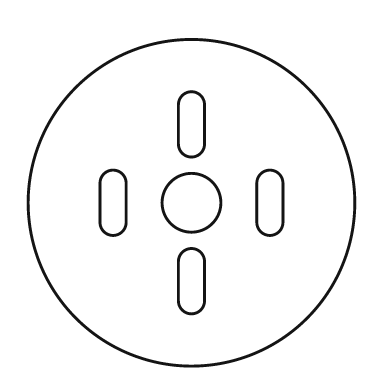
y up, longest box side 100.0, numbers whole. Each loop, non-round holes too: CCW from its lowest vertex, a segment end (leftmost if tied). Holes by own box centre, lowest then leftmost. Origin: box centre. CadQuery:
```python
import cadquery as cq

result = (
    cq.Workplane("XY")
    .moveTo(0.0, 0.0)
    .circle(50.0)
    .moveTo(-4.0, -30.0)
    .threePointArc((0.0, -34.0), (4.0, -30.0))
    .lineTo(4.0, -18.0)
    .threePointArc((0.0, -14.0), (-4.0, -18.0))
    .close()
    .moveTo(-28.0, -6.0)
    .threePointArc((-24.0, -10.0), (-20.0, -6.0))
    .lineTo(-20.0, 6.0)
    .threePointArc((-24.0, 10.0), (-28.0, 6.0))
    .close()
    .moveTo(0.0, 0.0)
    .circle(9.0)
    .moveTo(20.0, -6.0)
    .threePointArc((24.0, -10.0), (28.0, -6.0))
    .lineTo(28.0, 6.0)
    .threePointArc((24.0, 10.0), (20.0, 6.0))
    .close()
    .moveTo(-4.0, 18.0)
    .threePointArc((0.0, 14.0), (4.0, 18.0))
    .lineTo(4.0, 30.0)
    .threePointArc((0.0, 34.0), (-4.0, 30.0))
    .close()
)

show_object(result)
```